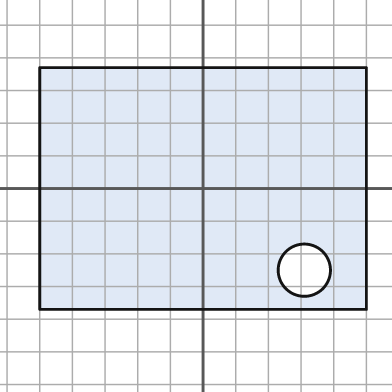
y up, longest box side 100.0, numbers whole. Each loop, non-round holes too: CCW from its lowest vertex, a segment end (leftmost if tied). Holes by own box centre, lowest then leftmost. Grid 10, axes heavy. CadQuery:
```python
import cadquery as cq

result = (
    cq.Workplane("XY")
    .moveTo(-50.0, -37.0)
    .lineTo(50.0, -37.0)
    .lineTo(50.0, 37.0)
    .lineTo(-50.0, 37.0)
    .close()
    .moveTo(31.0, -25.0)
    .circle(8.0)
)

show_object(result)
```